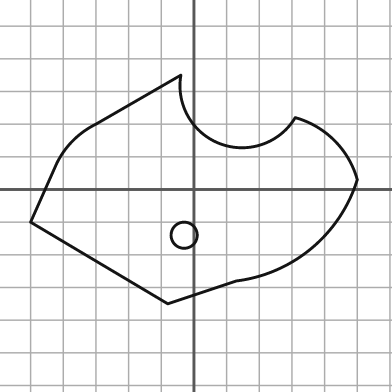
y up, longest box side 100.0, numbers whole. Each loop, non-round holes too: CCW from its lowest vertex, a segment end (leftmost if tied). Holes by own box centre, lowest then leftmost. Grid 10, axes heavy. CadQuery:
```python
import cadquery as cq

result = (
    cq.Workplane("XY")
    .moveTo(-8.0, -35.0)
    .lineTo(13.0, -28.0)
    .threePointArc((36.0, -18.0), (50.0, 3.0))
    .threePointArc((43.0, 15.0), (31.0, 22.0))
    .threePointArc((8.0, 14.0), (-4.0, 35.0))
    .lineTo(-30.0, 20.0)
    .threePointArc((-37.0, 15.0), (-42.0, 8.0))
    .lineTo(-50.0, -10.0)
    .close()
    .moveTo(-3.0, -14.0)
    .circle(4.0)
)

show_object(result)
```